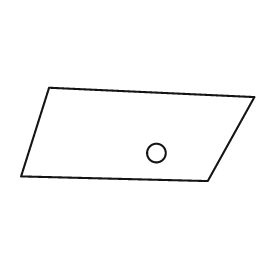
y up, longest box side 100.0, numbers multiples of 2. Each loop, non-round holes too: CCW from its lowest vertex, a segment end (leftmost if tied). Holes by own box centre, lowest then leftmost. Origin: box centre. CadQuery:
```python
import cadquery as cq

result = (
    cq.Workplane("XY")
    .moveTo(30.0, -20.0)
    .lineTo(50.0, 16.0)
    .lineTo(-38.0, 20.0)
    .lineTo(-50.0, -18.0)
    .close()
    .moveTo(8.0, -8.0)
    .circle(4.0)
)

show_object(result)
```